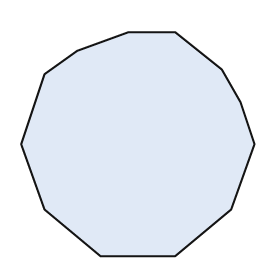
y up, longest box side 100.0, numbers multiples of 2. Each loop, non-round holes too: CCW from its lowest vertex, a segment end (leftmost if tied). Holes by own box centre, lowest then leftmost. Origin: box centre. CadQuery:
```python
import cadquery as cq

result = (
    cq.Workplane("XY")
    .moveTo(-16.0, -48.0)
    .lineTo(16.0, -48.0)
    .lineTo(40.0, -28.0)
    .lineTo(50.0, 0.0)
    .lineTo(44.0, 18.0)
    .lineTo(36.0, 32.0)
    .lineTo(16.0, 48.0)
    .lineTo(-4.0, 48.0)
    .lineTo(-26.0, 40.0)
    .lineTo(-40.0, 30.0)
    .lineTo(-50.0, 0.0)
    .lineTo(-40.0, -28.0)
    .close()
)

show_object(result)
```